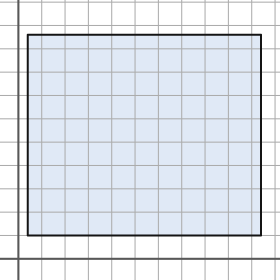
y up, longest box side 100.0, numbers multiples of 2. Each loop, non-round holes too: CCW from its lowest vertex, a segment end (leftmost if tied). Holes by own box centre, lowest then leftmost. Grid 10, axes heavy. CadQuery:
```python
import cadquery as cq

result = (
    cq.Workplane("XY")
    .moveTo(4.0, 10.0)
    .lineTo(104.0, 10.0)
    .lineTo(104.0, 96.0)
    .lineTo(4.0, 96.0)
    .close()
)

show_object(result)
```